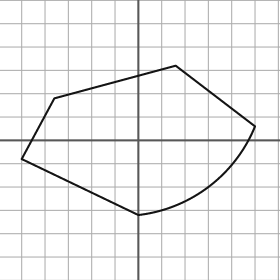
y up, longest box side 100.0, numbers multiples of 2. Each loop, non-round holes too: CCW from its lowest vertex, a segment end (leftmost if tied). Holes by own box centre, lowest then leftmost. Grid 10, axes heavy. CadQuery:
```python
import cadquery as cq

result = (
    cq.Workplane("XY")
    .moveTo(0.0, -32.0)
    .threePointArc((30.0, -20.0), (50.0, 6.0))
    .lineTo(16.0, 32.0)
    .lineTo(-36.0, 18.0)
    .lineTo(-50.0, -8.0)
    .close()
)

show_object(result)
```